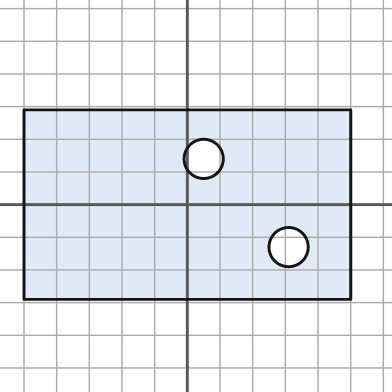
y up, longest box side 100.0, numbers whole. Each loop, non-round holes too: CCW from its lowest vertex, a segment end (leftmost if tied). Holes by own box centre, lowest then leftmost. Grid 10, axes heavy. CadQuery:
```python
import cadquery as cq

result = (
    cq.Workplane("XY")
    .moveTo(-50.0, -29.0)
    .lineTo(50.0, -29.0)
    .lineTo(50.0, 29.0)
    .lineTo(-50.0, 29.0)
    .close()
    .moveTo(31.0, -13.0)
    .circle(6.0)
    .moveTo(5.0, 14.0)
    .circle(6.0)
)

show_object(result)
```